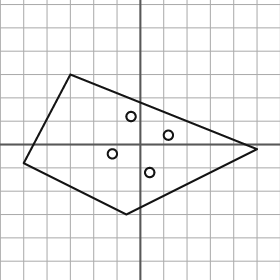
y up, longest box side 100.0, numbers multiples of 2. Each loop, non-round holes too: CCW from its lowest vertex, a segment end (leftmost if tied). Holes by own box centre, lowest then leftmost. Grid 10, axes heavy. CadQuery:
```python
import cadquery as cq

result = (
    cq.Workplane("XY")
    .moveTo(-6.0, -30.0)
    .lineTo(50.0, -2.0)
    .lineTo(-30.0, 30.0)
    .lineTo(-50.0, -8.0)
    .close()
    .moveTo(4.0, -12.0)
    .circle(2.0)
    .moveTo(-12.0, -4.0)
    .circle(2.0)
    .moveTo(12.0, 4.0)
    .circle(2.0)
    .moveTo(-4.0, 12.0)
    .circle(2.0)
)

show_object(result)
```